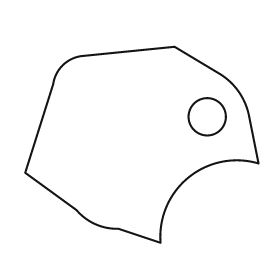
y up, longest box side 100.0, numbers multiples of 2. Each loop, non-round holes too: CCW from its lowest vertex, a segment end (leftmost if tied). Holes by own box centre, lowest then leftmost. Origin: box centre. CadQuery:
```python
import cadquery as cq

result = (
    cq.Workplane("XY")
    .moveTo(8.0, -42.0)
    .threePointArc((20.0, -14.0), (50.0, -8.0))
    .lineTo(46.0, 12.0)
    .threePointArc((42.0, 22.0), (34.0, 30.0))
    .lineTo(14.0, 42.0)
    .lineTo(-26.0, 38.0)
    .threePointArc((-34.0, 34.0), (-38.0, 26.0))
    .lineTo(-50.0, -12.0)
    .lineTo(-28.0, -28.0)
    .threePointArc((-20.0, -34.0), (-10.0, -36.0))
    .close()
    .moveTo(28.0, 12.0)
    .circle(8.0)
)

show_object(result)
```